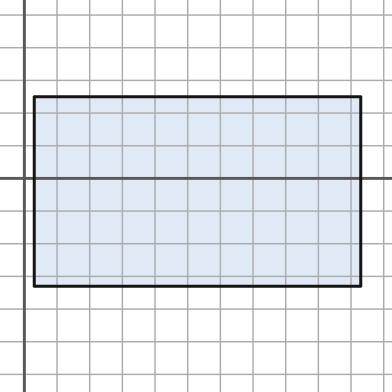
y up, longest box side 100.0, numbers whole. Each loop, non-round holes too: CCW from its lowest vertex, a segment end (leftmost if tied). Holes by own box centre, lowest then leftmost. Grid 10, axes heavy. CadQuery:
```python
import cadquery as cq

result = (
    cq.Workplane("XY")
    .moveTo(3.0, -33.0)
    .lineTo(103.0, -33.0)
    .lineTo(103.0, 25.0)
    .lineTo(3.0, 25.0)
    .close()
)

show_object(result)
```